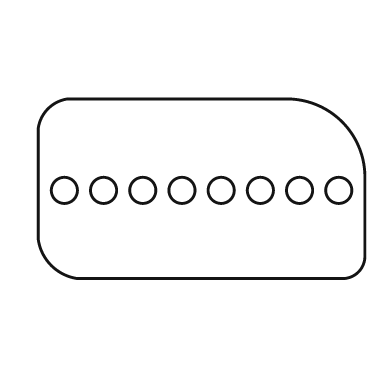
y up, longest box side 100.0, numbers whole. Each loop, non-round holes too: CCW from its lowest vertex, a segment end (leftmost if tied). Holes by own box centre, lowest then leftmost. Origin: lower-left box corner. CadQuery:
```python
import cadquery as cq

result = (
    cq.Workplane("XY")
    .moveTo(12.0, 0.0)
    .lineTo(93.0, 0.0)
    .threePointArc((98.0, 2.0), (100.0, 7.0))
    .lineTo(100.0, 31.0)
    .threePointArc((93.0, 48.0), (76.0, 55.0))
    .lineTo(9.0, 55.0)
    .threePointArc((3.0, 52.0), (0.0, 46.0))
    .lineTo(0.0, 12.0)
    .threePointArc((4.0, 4.0), (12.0, 0.0))
    .close()
    .moveTo(8.0, 27.0)
    .circle(4.0)
    .moveTo(20.0, 27.0)
    .circle(4.0)
    .moveTo(32.0, 27.0)
    .circle(4.0)
    .moveTo(44.0, 27.0)
    .circle(4.0)
    .moveTo(56.0, 27.0)
    .circle(4.0)
    .moveTo(68.0, 27.0)
    .circle(4.0)
    .moveTo(80.0, 27.0)
    .circle(4.0)
    .moveTo(92.0, 27.0)
    .circle(4.0)
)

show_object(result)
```